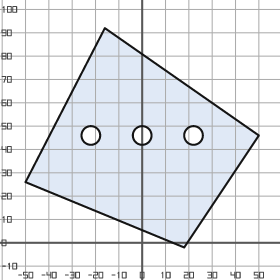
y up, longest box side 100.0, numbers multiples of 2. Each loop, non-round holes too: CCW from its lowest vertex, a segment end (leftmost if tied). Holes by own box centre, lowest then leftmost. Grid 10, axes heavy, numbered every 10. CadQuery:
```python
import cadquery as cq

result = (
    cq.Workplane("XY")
    .moveTo(18.0, -2.0)
    .lineTo(50.0, 46.0)
    .lineTo(-16.0, 92.0)
    .lineTo(-50.0, 26.0)
    .close()
    .moveTo(-22.0, 46.0)
    .circle(4.0)
    .moveTo(0.0, 46.0)
    .circle(4.0)
    .moveTo(22.0, 46.0)
    .circle(4.0)
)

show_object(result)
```